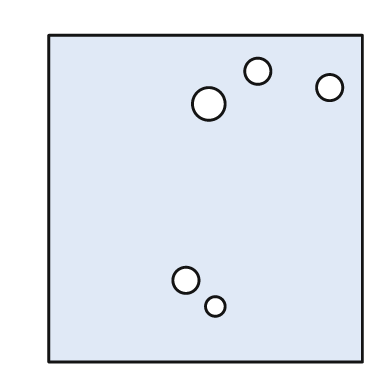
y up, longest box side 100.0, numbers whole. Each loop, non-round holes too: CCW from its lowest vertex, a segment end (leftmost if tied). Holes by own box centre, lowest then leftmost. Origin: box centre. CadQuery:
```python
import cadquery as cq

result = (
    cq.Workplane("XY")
    .moveTo(-48.0, -50.0)
    .lineTo(48.0, -50.0)
    .lineTo(48.0, 50.0)
    .lineTo(-48.0, 50.0)
    .close()
    .moveTo(3.0, -33.0)
    .circle(3.0)
    .moveTo(-6.0, -25.0)
    .circle(4.0)
    .moveTo(1.0, 29.0)
    .circle(5.0)
    .moveTo(38.0, 34.0)
    .circle(4.0)
    .moveTo(16.0, 39.0)
    .circle(4.0)
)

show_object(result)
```